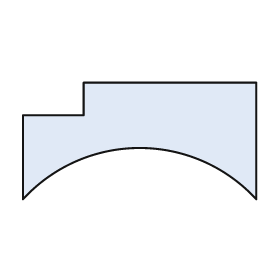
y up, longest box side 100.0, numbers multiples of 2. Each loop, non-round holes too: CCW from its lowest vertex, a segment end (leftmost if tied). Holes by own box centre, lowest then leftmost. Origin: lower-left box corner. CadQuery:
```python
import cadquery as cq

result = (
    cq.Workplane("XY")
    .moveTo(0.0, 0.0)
    .threePointArc((50.0, 22.0), (100.0, 0.0))
    .lineTo(100.0, 50.0)
    .lineTo(26.0, 50.0)
    .lineTo(26.0, 36.0)
    .lineTo(0.0, 36.0)
    .close()
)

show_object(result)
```